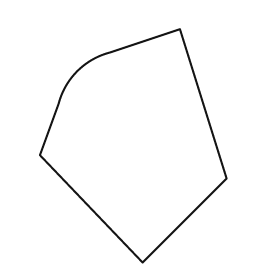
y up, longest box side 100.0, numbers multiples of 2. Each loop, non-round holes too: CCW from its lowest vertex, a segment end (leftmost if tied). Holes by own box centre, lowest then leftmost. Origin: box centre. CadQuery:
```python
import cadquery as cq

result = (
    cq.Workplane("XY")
    .moveTo(4.0, -50.0)
    .lineTo(40.0, -14.0)
    .lineTo(20.0, 50.0)
    .lineTo(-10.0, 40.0)
    .threePointArc((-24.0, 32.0), (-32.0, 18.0))
    .lineTo(-40.0, -4.0)
    .close()
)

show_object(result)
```